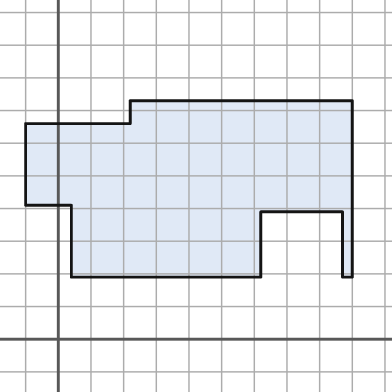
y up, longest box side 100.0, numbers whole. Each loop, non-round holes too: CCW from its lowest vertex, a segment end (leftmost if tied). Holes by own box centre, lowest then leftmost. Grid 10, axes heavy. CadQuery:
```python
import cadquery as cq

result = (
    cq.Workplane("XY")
    .moveTo(4.0, 19.0)
    .lineTo(62.0, 19.0)
    .lineTo(62.0, 39.0)
    .lineTo(87.0, 39.0)
    .lineTo(87.0, 19.0)
    .lineTo(90.0, 19.0)
    .lineTo(90.0, 73.0)
    .lineTo(22.0, 73.0)
    .lineTo(22.0, 66.0)
    .lineTo(-10.0, 66.0)
    .lineTo(-10.0, 41.0)
    .lineTo(4.0, 41.0)
    .close()
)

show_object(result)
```